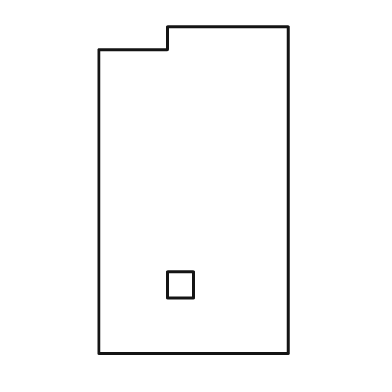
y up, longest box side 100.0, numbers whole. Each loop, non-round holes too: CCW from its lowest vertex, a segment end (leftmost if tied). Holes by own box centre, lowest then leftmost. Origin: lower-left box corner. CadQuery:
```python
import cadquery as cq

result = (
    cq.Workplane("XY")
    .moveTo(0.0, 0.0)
    .lineTo(58.0, 0.0)
    .lineTo(58.0, 100.0)
    .lineTo(21.0, 100.0)
    .lineTo(21.0, 93.0)
    .lineTo(0.0, 93.0)
    .close()
    .moveTo(21.0, 17.0)
    .lineTo(29.0, 17.0)
    .lineTo(29.0, 25.0)
    .lineTo(21.0, 25.0)
    .close()
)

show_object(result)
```